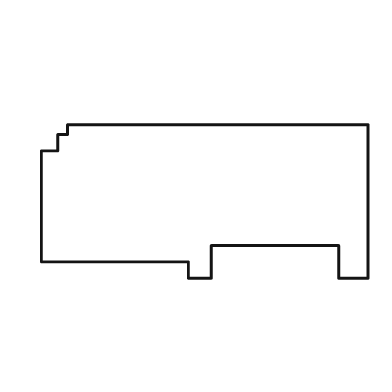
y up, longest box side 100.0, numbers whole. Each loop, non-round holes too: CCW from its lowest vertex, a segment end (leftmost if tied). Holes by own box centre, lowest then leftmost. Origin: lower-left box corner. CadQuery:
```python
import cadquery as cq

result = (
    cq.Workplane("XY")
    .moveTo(45.0, 0.0)
    .lineTo(52.0, 0.0)
    .lineTo(52.0, 10.0)
    .lineTo(91.0, 10.0)
    .lineTo(91.0, 0.0)
    .lineTo(100.0, 0.0)
    .lineTo(100.0, 47.0)
    .lineTo(8.0, 47.0)
    .lineTo(8.0, 44.0)
    .lineTo(5.0, 44.0)
    .lineTo(5.0, 39.0)
    .lineTo(0.0, 39.0)
    .lineTo(0.0, 5.0)
    .lineTo(45.0, 5.0)
    .close()
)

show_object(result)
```